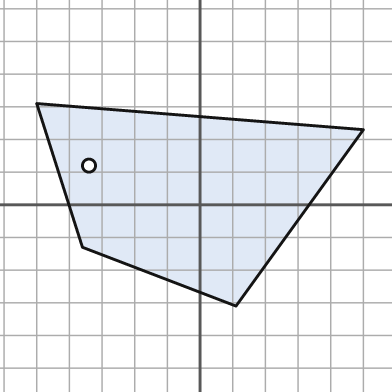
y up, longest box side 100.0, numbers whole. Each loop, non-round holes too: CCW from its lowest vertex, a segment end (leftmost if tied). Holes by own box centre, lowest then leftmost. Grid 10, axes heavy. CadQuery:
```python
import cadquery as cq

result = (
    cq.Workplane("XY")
    .moveTo(11.0, -31.0)
    .lineTo(50.0, 23.0)
    .lineTo(-50.0, 31.0)
    .lineTo(-36.0, -13.0)
    .close()
    .moveTo(-34.0, 12.0)
    .circle(2.0)
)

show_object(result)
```